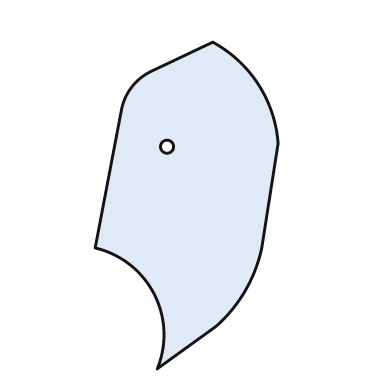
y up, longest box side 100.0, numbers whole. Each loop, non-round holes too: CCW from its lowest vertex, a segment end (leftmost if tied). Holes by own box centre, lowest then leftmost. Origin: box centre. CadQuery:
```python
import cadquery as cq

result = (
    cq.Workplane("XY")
    .moveTo(-9.0, -50.0)
    .lineTo(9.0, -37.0)
    .threePointArc((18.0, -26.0), (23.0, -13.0))
    .lineTo(28.0, 19.0)
    .threePointArc((22.0, 37.0), (8.0, 50.0))
    .lineTo(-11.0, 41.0)
    .threePointArc((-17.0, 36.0), (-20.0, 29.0))
    .lineTo(-28.0, -13.0)
    .threePointArc((-10.0, -27.0), (-9.0, -50.0))
    .close()
    .moveTo(-6.0, 18.0)
    .circle(2.0)
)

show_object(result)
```